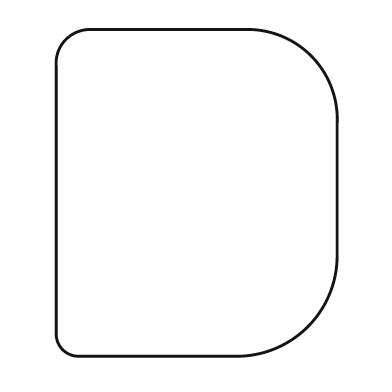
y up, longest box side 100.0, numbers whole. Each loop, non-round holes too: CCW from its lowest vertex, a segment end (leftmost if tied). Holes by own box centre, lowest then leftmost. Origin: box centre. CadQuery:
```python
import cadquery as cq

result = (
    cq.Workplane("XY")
    .moveTo(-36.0, -50.0)
    .lineTo(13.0, -50.0)
    .threePointArc((34.0, -41.0), (43.0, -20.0))
    .lineTo(43.0, 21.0)
    .threePointArc((35.0, 42.0), (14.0, 50.0))
    .lineTo(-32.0, 50.0)
    .threePointArc((-40.0, 47.0), (-43.0, 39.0))
    .lineTo(-43.0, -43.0)
    .threePointArc((-41.0, -48.0), (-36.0, -50.0))
    .close()
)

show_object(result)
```